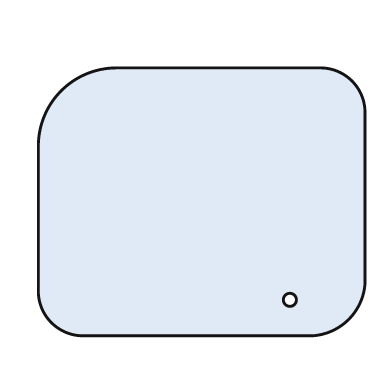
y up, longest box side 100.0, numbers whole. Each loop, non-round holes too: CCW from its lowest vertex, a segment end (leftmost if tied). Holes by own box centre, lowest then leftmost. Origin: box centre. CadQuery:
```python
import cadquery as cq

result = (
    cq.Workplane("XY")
    .moveTo(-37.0, -41.0)
    .lineTo(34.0, -41.0)
    .threePointArc((45.0, -36.0), (50.0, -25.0))
    .lineTo(50.0, 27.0)
    .threePointArc((46.0, 37.0), (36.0, 41.0))
    .lineTo(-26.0, 41.0)
    .threePointArc((-43.0, 34.0), (-50.0, 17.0))
    .lineTo(-50.0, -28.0)
    .threePointArc((-46.0, -37.0), (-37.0, -41.0))
    .close()
    .moveTo(27.0, -30.0)
    .circle(2.0)
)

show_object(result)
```